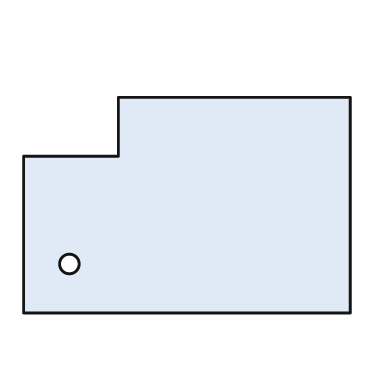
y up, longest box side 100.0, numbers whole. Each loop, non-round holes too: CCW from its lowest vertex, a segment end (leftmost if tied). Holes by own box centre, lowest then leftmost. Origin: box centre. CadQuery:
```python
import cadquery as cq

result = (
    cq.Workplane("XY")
    .moveTo(-50.0, -33.0)
    .lineTo(50.0, -33.0)
    .lineTo(50.0, 33.0)
    .lineTo(-21.0, 33.0)
    .lineTo(-21.0, 15.0)
    .lineTo(-50.0, 15.0)
    .close()
    .moveTo(-36.0, -18.0)
    .circle(3.0)
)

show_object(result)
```